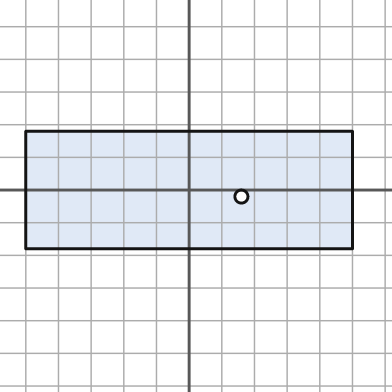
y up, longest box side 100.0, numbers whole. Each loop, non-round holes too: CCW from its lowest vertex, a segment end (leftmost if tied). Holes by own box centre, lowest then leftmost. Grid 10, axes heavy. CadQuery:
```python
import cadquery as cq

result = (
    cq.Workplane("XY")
    .moveTo(-50.0, -18.0)
    .lineTo(50.0, -18.0)
    .lineTo(50.0, 18.0)
    .lineTo(-50.0, 18.0)
    .close()
    .moveTo(16.0, -2.0)
    .circle(2.0)
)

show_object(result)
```